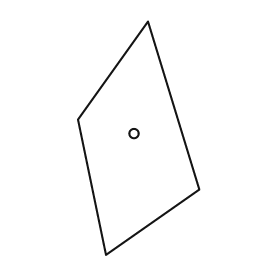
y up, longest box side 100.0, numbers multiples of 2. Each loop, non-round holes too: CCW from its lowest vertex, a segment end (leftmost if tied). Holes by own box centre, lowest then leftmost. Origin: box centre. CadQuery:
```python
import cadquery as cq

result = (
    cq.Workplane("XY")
    .moveTo(-14.0, -50.0)
    .lineTo(26.0, -22.0)
    .lineTo(4.0, 50.0)
    .lineTo(-26.0, 8.0)
    .close()
    .moveTo(-2.0, 2.0)
    .circle(2.0)
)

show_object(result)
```